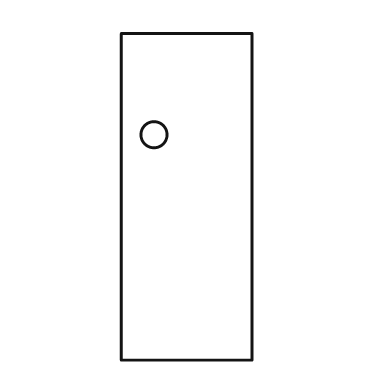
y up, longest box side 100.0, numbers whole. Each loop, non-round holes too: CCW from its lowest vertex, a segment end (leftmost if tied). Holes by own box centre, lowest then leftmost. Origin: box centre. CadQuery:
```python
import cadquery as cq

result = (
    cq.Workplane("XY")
    .moveTo(-20.0, -50.0)
    .lineTo(20.0, -50.0)
    .lineTo(20.0, 50.0)
    .lineTo(-20.0, 50.0)
    .close()
    .moveTo(-10.0, 19.0)
    .circle(4.0)
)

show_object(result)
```